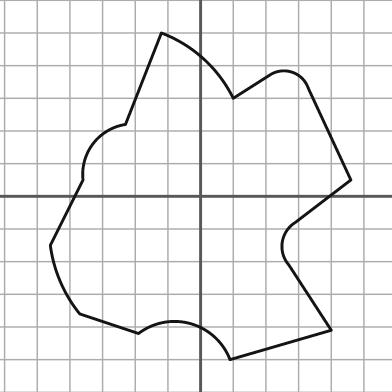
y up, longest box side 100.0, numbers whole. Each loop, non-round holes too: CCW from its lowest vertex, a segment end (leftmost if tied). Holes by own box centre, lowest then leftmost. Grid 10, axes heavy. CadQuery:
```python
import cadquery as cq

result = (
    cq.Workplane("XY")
    .moveTo(9.0, -50.0)
    .lineTo(40.0, -41.0)
    .lineTo(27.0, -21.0)
    .threePointArc((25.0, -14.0), (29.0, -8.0))
    .lineTo(46.0, 5.0)
    .lineTo(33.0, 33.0)
    .threePointArc((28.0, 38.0), (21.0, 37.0))
    .lineTo(10.0, 30.0)
    .threePointArc((1.0, 42.0), (-12.0, 50.0))
    .lineTo(-23.0, 22.0)
    .threePointArc((-33.0, 16.0), (-36.0, 5.0))
    .lineTo(-46.0, -15.0)
    .threePointArc((-43.0, -26.0), (-37.0, -36.0))
    .lineTo(-19.0, -42.0)
    .threePointArc((-3.0, -39.0), (9.0, -50.0))
    .close()
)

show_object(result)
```